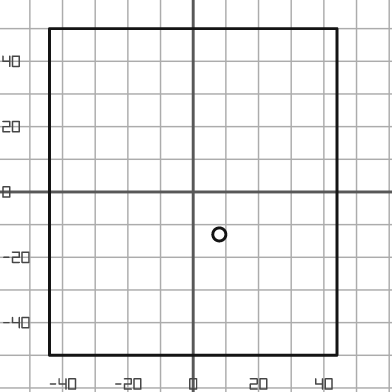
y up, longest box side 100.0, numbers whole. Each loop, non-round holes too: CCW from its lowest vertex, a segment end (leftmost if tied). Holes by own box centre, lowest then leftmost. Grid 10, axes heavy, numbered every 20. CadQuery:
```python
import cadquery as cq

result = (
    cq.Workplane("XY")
    .moveTo(-44.0, -50.0)
    .lineTo(44.0, -50.0)
    .lineTo(44.0, 50.0)
    .lineTo(-44.0, 50.0)
    .close()
    .moveTo(8.0, -13.0)
    .circle(2.0)
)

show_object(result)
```